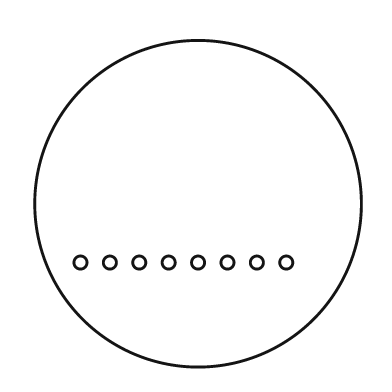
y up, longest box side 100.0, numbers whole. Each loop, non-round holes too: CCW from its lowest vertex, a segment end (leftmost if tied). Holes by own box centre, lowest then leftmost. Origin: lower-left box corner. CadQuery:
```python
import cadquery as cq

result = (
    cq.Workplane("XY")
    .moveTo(50.0, 50.0)
    .circle(50.0)
    .moveTo(14.0, 32.0)
    .circle(2.0)
    .moveTo(23.0, 32.0)
    .circle(2.0)
    .moveTo(32.0, 32.0)
    .circle(2.0)
    .moveTo(41.0, 32.0)
    .circle(2.0)
    .moveTo(50.0, 32.0)
    .circle(2.0)
    .moveTo(59.0, 32.0)
    .circle(2.0)
    .moveTo(68.0, 32.0)
    .circle(2.0)
    .moveTo(77.0, 32.0)
    .circle(2.0)
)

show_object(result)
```